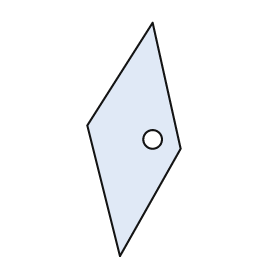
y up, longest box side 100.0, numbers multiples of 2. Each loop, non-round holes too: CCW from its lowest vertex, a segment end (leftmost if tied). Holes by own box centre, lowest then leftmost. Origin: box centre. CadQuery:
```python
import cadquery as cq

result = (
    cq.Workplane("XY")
    .moveTo(-6.0, -50.0)
    .lineTo(20.0, -4.0)
    .lineTo(8.0, 50.0)
    .lineTo(-20.0, 6.0)
    .close()
    .moveTo(8.0, 0.0)
    .circle(4.0)
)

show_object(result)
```